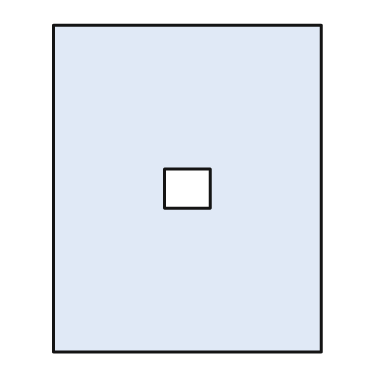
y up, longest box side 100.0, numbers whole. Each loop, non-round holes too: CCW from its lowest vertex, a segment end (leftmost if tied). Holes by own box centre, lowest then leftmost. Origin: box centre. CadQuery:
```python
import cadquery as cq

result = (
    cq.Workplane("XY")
    .moveTo(-41.0, -50.0)
    .lineTo(41.0, -50.0)
    .lineTo(41.0, 50.0)
    .lineTo(-41.0, 50.0)
    .close()
    .moveTo(-7.0, -6.0)
    .lineTo(7.0, -6.0)
    .lineTo(7.0, 6.0)
    .lineTo(-7.0, 6.0)
    .close()
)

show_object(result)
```